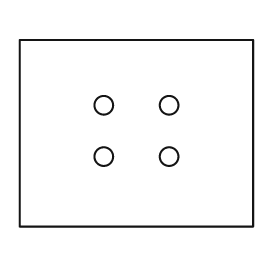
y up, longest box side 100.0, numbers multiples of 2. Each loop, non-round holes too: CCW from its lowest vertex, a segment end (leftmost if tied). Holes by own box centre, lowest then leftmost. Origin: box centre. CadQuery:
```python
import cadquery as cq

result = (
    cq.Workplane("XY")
    .moveTo(-50.0, -40.0)
    .lineTo(50.0, -40.0)
    .lineTo(50.0, 40.0)
    .lineTo(-50.0, 40.0)
    .close()
    .moveTo(-14.0, -10.0)
    .circle(4.0)
    .moveTo(14.0, -10.0)
    .circle(4.0)
    .moveTo(-14.0, 12.0)
    .circle(4.0)
    .moveTo(14.0, 12.0)
    .circle(4.0)
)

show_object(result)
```